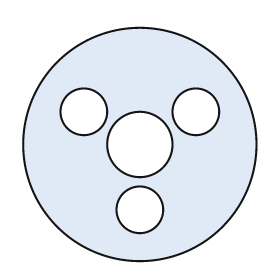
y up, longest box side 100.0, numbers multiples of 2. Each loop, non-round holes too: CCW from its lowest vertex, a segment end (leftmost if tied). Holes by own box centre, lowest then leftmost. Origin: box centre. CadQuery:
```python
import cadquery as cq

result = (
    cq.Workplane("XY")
    .moveTo(0.0, 0.0)
    .circle(50.0)
    .moveTo(0.0, -28.0)
    .circle(10.0)
    .moveTo(0.0, 0.0)
    .circle(14.0)
    .moveTo(-24.0, 14.0)
    .circle(10.0)
    .moveTo(24.0, 14.0)
    .circle(10.0)
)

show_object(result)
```